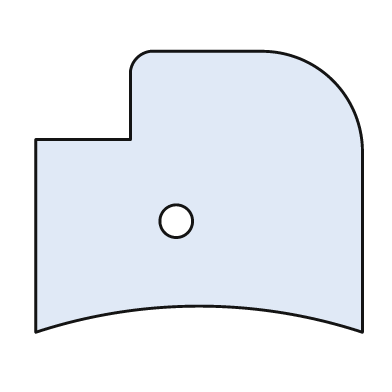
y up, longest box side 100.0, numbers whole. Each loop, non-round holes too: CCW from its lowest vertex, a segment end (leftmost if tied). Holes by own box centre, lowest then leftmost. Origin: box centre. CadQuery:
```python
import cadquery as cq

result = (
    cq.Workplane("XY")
    .moveTo(-50.0, -43.0)
    .threePointArc((0.0, -35.0), (50.0, -43.0))
    .lineTo(50.0, 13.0)
    .threePointArc((41.0, 34.0), (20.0, 43.0))
    .lineTo(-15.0, 43.0)
    .threePointArc((-19.0, 41.0), (-21.0, 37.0))
    .lineTo(-21.0, 16.0)
    .lineTo(-50.0, 16.0)
    .close()
    .moveTo(-7.0, -9.0)
    .circle(5.0)
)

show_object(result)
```